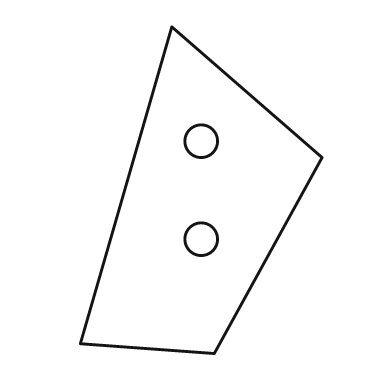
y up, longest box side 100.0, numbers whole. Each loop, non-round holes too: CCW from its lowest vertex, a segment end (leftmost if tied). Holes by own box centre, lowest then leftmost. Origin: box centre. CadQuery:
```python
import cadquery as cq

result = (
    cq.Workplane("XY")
    .moveTo(4.0, -50.0)
    .lineTo(37.0, 10.0)
    .lineTo(-9.0, 50.0)
    .lineTo(-37.0, -47.0)
    .close()
    .moveTo(0.0, -15.0)
    .circle(5.0)
    .moveTo(0.0, 15.0)
    .circle(5.0)
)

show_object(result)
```